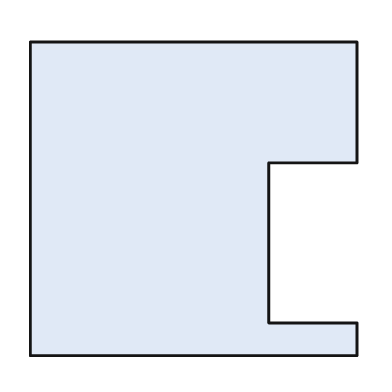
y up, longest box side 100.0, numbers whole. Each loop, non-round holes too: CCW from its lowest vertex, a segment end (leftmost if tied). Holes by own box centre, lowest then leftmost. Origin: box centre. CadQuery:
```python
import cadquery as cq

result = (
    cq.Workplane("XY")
    .moveTo(-50.0, -48.0)
    .lineTo(50.0, -48.0)
    .lineTo(50.0, -38.0)
    .lineTo(23.0, -38.0)
    .lineTo(23.0, 11.0)
    .lineTo(50.0, 11.0)
    .lineTo(50.0, 48.0)
    .lineTo(-50.0, 48.0)
    .close()
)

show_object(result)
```